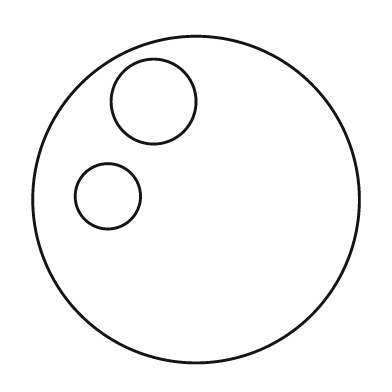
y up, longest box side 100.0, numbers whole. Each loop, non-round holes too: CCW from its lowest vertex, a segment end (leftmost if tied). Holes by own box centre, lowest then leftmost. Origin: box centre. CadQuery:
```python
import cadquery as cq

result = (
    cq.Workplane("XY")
    .moveTo(0.0, 0.0)
    .circle(50.0)
    .moveTo(-27.0, 1.0)
    .circle(10.0)
    .moveTo(-13.0, 30.0)
    .circle(13.0)
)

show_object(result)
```